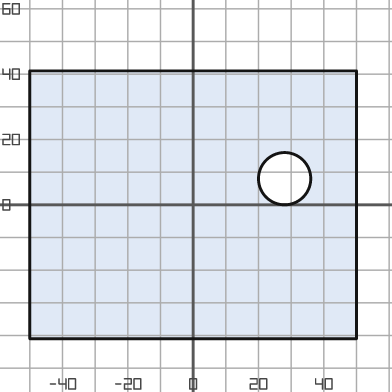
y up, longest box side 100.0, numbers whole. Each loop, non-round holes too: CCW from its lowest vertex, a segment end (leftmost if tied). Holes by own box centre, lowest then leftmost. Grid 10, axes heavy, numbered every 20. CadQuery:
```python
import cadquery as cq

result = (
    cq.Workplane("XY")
    .moveTo(-50.0, -41.0)
    .lineTo(50.0, -41.0)
    .lineTo(50.0, 41.0)
    .lineTo(-50.0, 41.0)
    .close()
    .moveTo(28.0, 8.0)
    .circle(8.0)
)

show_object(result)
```